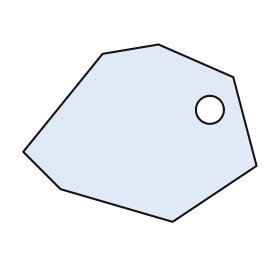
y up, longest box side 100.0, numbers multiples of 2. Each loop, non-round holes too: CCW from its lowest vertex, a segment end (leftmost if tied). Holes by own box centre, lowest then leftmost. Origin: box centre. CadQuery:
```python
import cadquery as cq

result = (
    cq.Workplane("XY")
    .moveTo(14.0, -38.0)
    .lineTo(50.0, -14.0)
    .lineTo(40.0, 24.0)
    .lineTo(8.0, 38.0)
    .lineTo(-16.0, 34.0)
    .lineTo(-50.0, -8.0)
    .lineTo(-34.0, -24.0)
    .close()
    .moveTo(30.0, 10.0)
    .circle(6.0)
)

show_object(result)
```